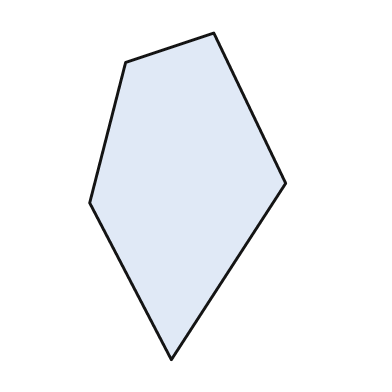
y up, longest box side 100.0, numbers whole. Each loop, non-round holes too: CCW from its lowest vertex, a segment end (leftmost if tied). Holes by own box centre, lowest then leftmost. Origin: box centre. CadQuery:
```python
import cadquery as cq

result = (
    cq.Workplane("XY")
    .moveTo(-5.0, -50.0)
    .lineTo(30.0, 4.0)
    .lineTo(8.0, 50.0)
    .lineTo(-19.0, 41.0)
    .lineTo(-30.0, -2.0)
    .close()
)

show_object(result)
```